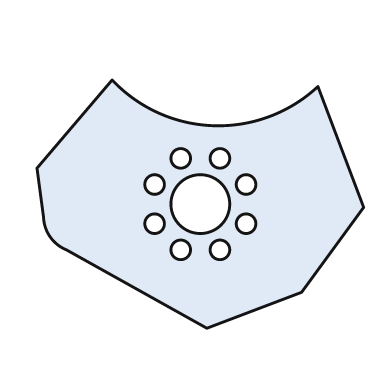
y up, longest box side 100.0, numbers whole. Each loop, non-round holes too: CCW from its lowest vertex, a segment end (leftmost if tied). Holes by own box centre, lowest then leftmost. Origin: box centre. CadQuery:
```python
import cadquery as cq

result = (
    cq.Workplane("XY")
    .moveTo(2.0, -38.0)
    .lineTo(31.0, -27.0)
    .lineTo(50.0, -1.0)
    .lineTo(36.0, 36.0)
    .threePointArc((4.0, 24.0), (-27.0, 38.0))
    .lineTo(-50.0, 11.0)
    .lineTo(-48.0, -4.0)
    .threePointArc((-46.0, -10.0), (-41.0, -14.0))
    .close()
    .moveTo(-6.0, -14.0)
    .circle(3.0)
    .moveTo(6.0, -14.0)
    .circle(3.0)
    .moveTo(-14.0, -6.0)
    .circle(3.0)
    .moveTo(14.0, -6.0)
    .circle(3.0)
    .moveTo(0.0, 0.0)
    .circle(9.0)
    .moveTo(-14.0, 6.0)
    .circle(3.0)
    .moveTo(14.0, 6.0)
    .circle(3.0)
    .moveTo(-6.0, 14.0)
    .circle(3.0)
    .moveTo(6.0, 14.0)
    .circle(3.0)
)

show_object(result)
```